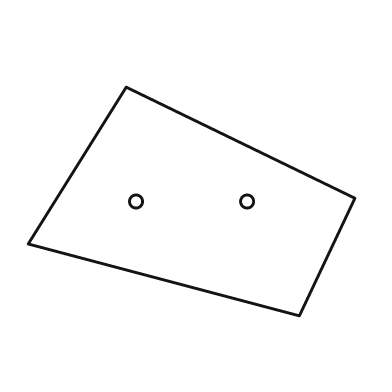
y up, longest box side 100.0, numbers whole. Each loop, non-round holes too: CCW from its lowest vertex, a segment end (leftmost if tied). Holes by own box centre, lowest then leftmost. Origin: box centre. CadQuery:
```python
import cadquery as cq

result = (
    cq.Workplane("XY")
    .moveTo(33.0, -35.0)
    .lineTo(50.0, 1.0)
    .lineTo(-20.0, 35.0)
    .lineTo(-50.0, -13.0)
    .close()
    .moveTo(-17.0, 0.0)
    .circle(2.0)
    .moveTo(17.0, 0.0)
    .circle(2.0)
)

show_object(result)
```